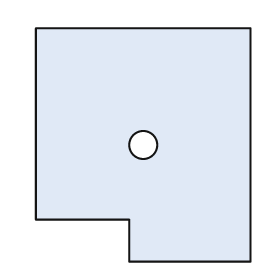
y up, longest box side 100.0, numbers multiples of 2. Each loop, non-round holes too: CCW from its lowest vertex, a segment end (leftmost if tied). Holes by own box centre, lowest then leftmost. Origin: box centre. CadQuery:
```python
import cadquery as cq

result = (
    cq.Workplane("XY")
    .moveTo(-6.0, -50.0)
    .lineTo(46.0, -50.0)
    .lineTo(46.0, 50.0)
    .lineTo(-46.0, 50.0)
    .lineTo(-46.0, -32.0)
    .lineTo(-6.0, -32.0)
    .close()
    .moveTo(0.0, 0.0)
    .circle(6.0)
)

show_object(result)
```